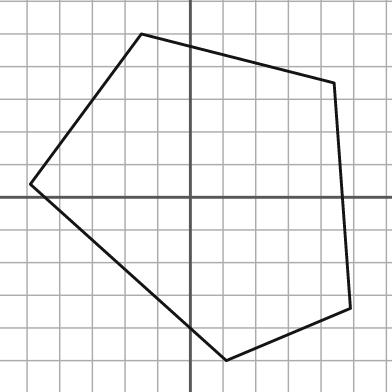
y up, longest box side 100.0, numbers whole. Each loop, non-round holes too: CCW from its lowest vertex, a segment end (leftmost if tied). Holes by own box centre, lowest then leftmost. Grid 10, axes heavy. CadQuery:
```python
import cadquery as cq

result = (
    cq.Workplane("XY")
    .moveTo(11.0, -50.0)
    .lineTo(49.0, -34.0)
    .lineTo(44.0, 35.0)
    .lineTo(-15.0, 50.0)
    .lineTo(-49.0, 4.0)
    .close()
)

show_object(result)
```